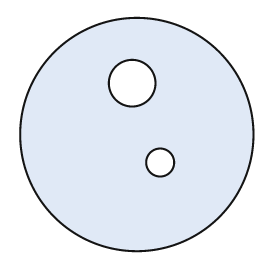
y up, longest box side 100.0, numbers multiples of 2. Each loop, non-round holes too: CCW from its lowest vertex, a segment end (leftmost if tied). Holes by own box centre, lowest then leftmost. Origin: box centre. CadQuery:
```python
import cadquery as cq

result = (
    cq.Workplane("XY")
    .moveTo(0.0, 0.0)
    .circle(50.0)
    .moveTo(10.0, -12.0)
    .circle(6.0)
    .moveTo(-2.0, 22.0)
    .circle(10.0)
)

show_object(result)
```